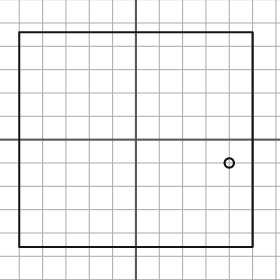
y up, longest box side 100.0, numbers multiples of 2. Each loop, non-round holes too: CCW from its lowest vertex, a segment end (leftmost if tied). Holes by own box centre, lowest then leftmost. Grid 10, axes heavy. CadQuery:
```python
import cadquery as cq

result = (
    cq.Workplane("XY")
    .moveTo(-50.0, -46.0)
    .lineTo(50.0, -46.0)
    .lineTo(50.0, 46.0)
    .lineTo(-50.0, 46.0)
    .close()
    .moveTo(40.0, -10.0)
    .circle(2.0)
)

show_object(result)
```